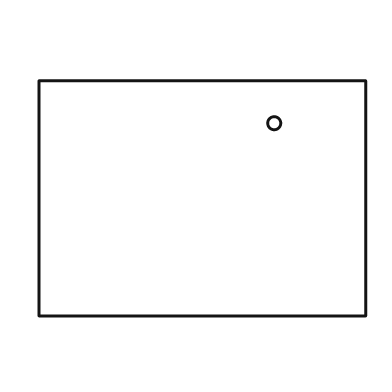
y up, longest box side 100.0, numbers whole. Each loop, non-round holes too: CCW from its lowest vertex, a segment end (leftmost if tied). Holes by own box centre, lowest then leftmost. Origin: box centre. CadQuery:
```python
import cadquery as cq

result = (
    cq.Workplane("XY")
    .moveTo(-50.0, -36.0)
    .lineTo(50.0, -36.0)
    .lineTo(50.0, 36.0)
    .lineTo(-50.0, 36.0)
    .close()
    .moveTo(22.0, 23.0)
    .circle(2.0)
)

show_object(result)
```